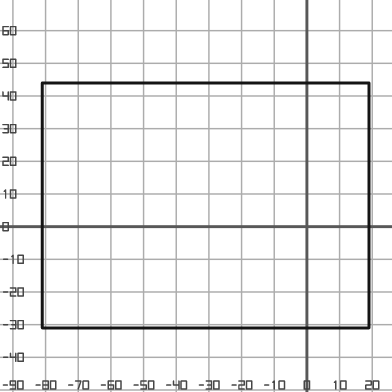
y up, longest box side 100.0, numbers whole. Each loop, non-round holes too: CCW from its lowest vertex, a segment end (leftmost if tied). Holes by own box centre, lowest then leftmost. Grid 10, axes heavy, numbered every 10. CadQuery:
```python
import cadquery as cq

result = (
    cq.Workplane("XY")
    .moveTo(-81.0, -31.0)
    .lineTo(19.0, -31.0)
    .lineTo(19.0, 44.0)
    .lineTo(-81.0, 44.0)
    .close()
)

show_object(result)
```